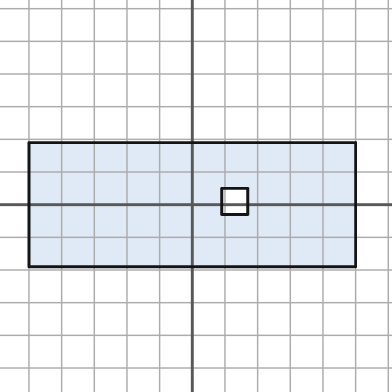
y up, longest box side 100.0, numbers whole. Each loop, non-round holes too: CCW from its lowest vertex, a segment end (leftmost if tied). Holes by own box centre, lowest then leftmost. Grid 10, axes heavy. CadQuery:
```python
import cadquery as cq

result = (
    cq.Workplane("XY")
    .moveTo(-50.0, -19.0)
    .lineTo(50.0, -19.0)
    .lineTo(50.0, 19.0)
    .lineTo(-50.0, 19.0)
    .close()
    .moveTo(9.0, -3.0)
    .lineTo(17.0, -3.0)
    .lineTo(17.0, 5.0)
    .lineTo(9.0, 5.0)
    .close()
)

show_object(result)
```